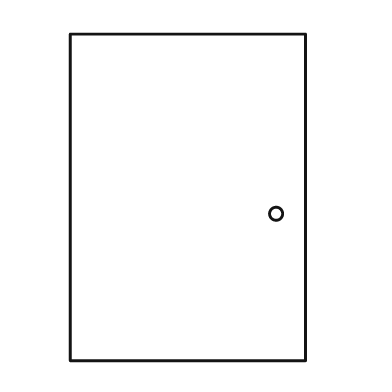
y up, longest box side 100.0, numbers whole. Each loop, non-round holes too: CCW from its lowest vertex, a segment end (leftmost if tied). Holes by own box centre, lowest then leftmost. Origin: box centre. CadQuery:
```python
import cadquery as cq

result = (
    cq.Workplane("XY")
    .moveTo(-36.0, -50.0)
    .lineTo(36.0, -50.0)
    .lineTo(36.0, 50.0)
    .lineTo(-36.0, 50.0)
    .close()
    .moveTo(27.0, -5.0)
    .circle(2.0)
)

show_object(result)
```